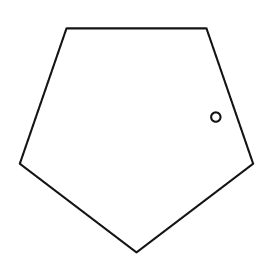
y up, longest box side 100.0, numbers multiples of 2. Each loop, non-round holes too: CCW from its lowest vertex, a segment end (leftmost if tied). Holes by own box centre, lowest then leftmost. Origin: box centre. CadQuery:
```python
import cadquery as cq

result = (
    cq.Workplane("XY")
    .moveTo(0.0, -48.0)
    .lineTo(50.0, -10.0)
    .lineTo(30.0, 48.0)
    .lineTo(-30.0, 48.0)
    .lineTo(-50.0, -10.0)
    .close()
    .moveTo(34.0, 10.0)
    .circle(2.0)
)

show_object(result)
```